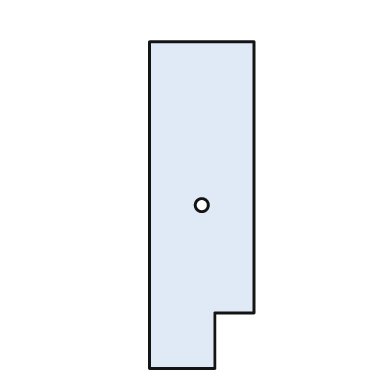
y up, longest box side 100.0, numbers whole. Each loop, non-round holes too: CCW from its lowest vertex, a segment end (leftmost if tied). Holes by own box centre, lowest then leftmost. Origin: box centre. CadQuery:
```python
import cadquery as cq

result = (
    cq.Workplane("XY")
    .moveTo(-16.0, -50.0)
    .lineTo(4.0, -50.0)
    .lineTo(4.0, -33.0)
    .lineTo(16.0, -33.0)
    .lineTo(16.0, 50.0)
    .lineTo(-16.0, 50.0)
    .close()
    .moveTo(0.0, 0.0)
    .circle(2.0)
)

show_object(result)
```